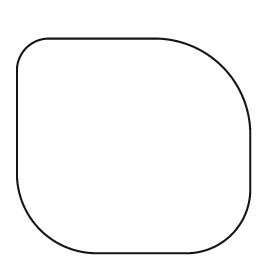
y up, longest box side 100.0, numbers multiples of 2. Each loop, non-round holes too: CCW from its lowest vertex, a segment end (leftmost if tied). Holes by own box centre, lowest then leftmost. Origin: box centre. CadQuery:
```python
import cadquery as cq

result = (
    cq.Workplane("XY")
    .moveTo(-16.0, -46.0)
    .lineTo(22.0, -46.0)
    .threePointArc((42.0, -38.0), (50.0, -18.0))
    .lineTo(50.0, 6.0)
    .threePointArc((38.0, 34.0), (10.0, 46.0))
    .lineTo(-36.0, 46.0)
    .threePointArc((-46.0, 42.0), (-50.0, 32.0))
    .lineTo(-50.0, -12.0)
    .threePointArc((-40.0, -36.0), (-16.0, -46.0))
    .close()
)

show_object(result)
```